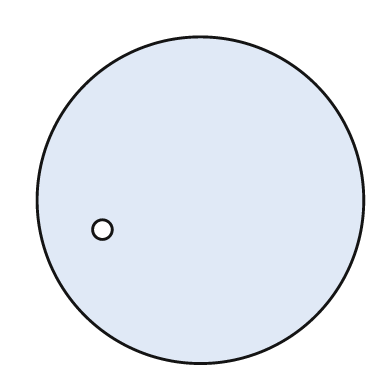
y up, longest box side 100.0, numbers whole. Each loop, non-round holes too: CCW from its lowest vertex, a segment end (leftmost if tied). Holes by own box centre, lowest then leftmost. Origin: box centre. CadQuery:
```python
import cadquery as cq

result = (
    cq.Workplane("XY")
    .moveTo(0.0, 0.0)
    .circle(50.0)
    .moveTo(-30.0, -9.0)
    .circle(3.0)
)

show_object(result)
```